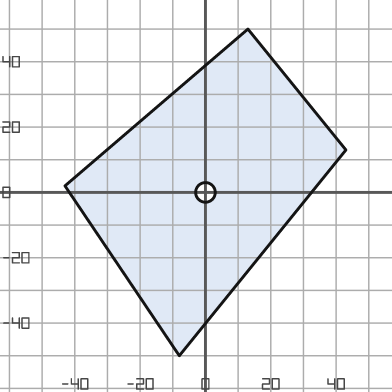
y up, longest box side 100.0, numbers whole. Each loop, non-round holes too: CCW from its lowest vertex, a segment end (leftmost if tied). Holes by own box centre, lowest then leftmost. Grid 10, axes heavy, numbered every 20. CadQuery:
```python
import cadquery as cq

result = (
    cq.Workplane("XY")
    .moveTo(-8.0, -50.0)
    .lineTo(43.0, 13.0)
    .lineTo(13.0, 50.0)
    .lineTo(-43.0, 2.0)
    .close()
    .moveTo(0.0, 0.0)
    .circle(3.0)
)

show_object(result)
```